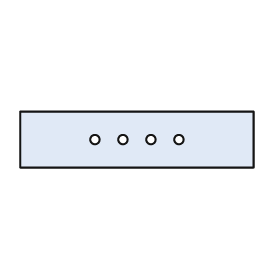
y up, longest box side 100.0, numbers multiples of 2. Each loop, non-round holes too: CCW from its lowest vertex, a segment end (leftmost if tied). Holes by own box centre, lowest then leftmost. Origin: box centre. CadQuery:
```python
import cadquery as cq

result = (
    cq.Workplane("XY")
    .moveTo(-50.0, -12.0)
    .lineTo(50.0, -12.0)
    .lineTo(50.0, 12.0)
    .lineTo(-50.0, 12.0)
    .close()
    .moveTo(-18.0, 0.0)
    .circle(2.0)
    .moveTo(-6.0, 0.0)
    .circle(2.0)
    .moveTo(6.0, 0.0)
    .circle(2.0)
    .moveTo(18.0, 0.0)
    .circle(2.0)
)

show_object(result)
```